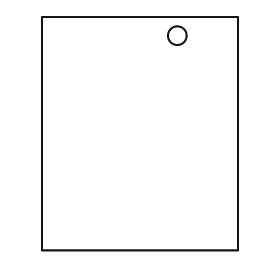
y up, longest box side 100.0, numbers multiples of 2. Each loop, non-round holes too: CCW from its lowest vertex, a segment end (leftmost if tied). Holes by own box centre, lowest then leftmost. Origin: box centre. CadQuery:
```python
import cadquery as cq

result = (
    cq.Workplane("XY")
    .moveTo(-42.0, -50.0)
    .lineTo(42.0, -50.0)
    .lineTo(42.0, 50.0)
    .lineTo(-42.0, 50.0)
    .close()
    .moveTo(16.0, 42.0)
    .circle(4.0)
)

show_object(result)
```